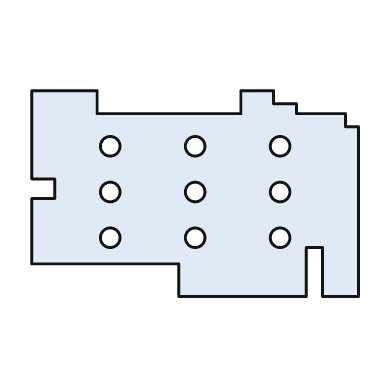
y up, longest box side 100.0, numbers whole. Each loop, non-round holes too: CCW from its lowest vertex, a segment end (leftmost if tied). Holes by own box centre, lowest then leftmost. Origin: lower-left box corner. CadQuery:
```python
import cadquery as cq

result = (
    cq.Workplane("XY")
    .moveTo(45.0, 0.0)
    .lineTo(84.0, 0.0)
    .lineTo(84.0, 15.0)
    .lineTo(89.0, 15.0)
    .lineTo(89.0, 0.0)
    .lineTo(100.0, 0.0)
    .lineTo(100.0, 52.0)
    .lineTo(96.0, 52.0)
    .lineTo(96.0, 56.0)
    .lineTo(81.0, 56.0)
    .lineTo(81.0, 59.0)
    .lineTo(74.0, 59.0)
    .lineTo(74.0, 63.0)
    .lineTo(64.0, 63.0)
    .lineTo(64.0, 56.0)
    .lineTo(20.0, 56.0)
    .lineTo(20.0, 63.0)
    .lineTo(0.0, 63.0)
    .lineTo(0.0, 36.0)
    .lineTo(7.0, 36.0)
    .lineTo(7.0, 30.0)
    .lineTo(0.0, 30.0)
    .lineTo(0.0, 10.0)
    .lineTo(45.0, 10.0)
    .close()
    .moveTo(24.0, 18.0)
    .circle(3.0)
    .moveTo(50.0, 18.0)
    .circle(3.0)
    .moveTo(76.0, 18.0)
    .circle(3.0)
    .moveTo(24.0, 32.0)
    .circle(3.0)
    .moveTo(50.0, 32.0)
    .circle(3.0)
    .moveTo(76.0, 32.0)
    .circle(3.0)
    .moveTo(24.0, 46.0)
    .circle(3.0)
    .moveTo(50.0, 46.0)
    .circle(3.0)
    .moveTo(76.0, 46.0)
    .circle(3.0)
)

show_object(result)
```